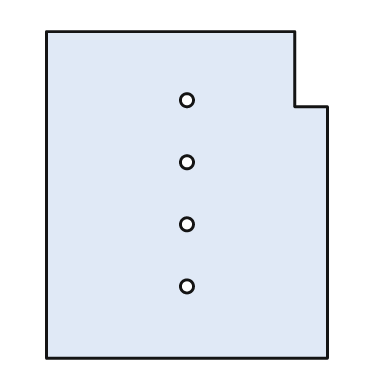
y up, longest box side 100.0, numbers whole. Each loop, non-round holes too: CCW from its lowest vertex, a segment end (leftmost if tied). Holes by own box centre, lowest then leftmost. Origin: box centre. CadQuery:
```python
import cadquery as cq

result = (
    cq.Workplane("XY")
    .moveTo(-43.0, -50.0)
    .lineTo(43.0, -50.0)
    .lineTo(43.0, 27.0)
    .lineTo(33.0, 27.0)
    .lineTo(33.0, 50.0)
    .lineTo(-43.0, 50.0)
    .close()
    .moveTo(0.0, -28.0)
    .circle(2.0)
    .moveTo(0.0, -9.0)
    .circle(2.0)
    .moveTo(0.0, 10.0)
    .circle(2.0)
    .moveTo(0.0, 29.0)
    .circle(2.0)
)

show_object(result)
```